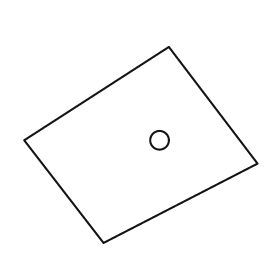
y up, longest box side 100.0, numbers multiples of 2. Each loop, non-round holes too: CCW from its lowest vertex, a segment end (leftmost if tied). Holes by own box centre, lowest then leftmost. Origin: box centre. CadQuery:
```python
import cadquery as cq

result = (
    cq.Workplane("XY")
    .moveTo(-16.0, -42.0)
    .lineTo(50.0, -8.0)
    .lineTo(12.0, 42.0)
    .lineTo(-50.0, 2.0)
    .close()
    .moveTo(8.0, 2.0)
    .circle(4.0)
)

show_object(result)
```